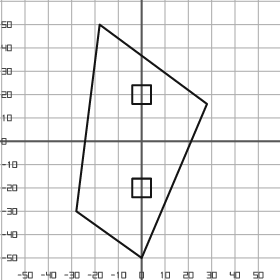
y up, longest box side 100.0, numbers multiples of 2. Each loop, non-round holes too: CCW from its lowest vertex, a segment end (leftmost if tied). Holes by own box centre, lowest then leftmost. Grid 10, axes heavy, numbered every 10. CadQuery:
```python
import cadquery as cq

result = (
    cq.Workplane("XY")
    .moveTo(0.0, -50.0)
    .lineTo(28.0, 16.0)
    .lineTo(-18.0, 50.0)
    .lineTo(-28.0, -30.0)
    .close()
    .moveTo(-4.0, -24.0)
    .lineTo(4.0, -24.0)
    .lineTo(4.0, -16.0)
    .lineTo(-4.0, -16.0)
    .close()
    .moveTo(-4.0, 16.0)
    .lineTo(4.0, 16.0)
    .lineTo(4.0, 24.0)
    .lineTo(-4.0, 24.0)
    .close()
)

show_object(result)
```